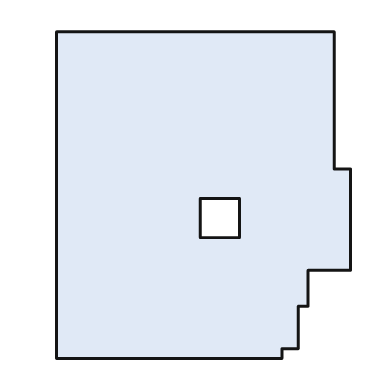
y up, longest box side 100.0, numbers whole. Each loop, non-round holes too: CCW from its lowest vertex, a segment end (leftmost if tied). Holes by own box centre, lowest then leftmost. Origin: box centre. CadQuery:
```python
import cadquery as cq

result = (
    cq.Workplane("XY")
    .moveTo(-45.0, -50.0)
    .lineTo(24.0, -50.0)
    .lineTo(24.0, -47.0)
    .lineTo(29.0, -47.0)
    .lineTo(29.0, -34.0)
    .lineTo(32.0, -34.0)
    .lineTo(32.0, -23.0)
    .lineTo(45.0, -23.0)
    .lineTo(45.0, 8.0)
    .lineTo(40.0, 8.0)
    .lineTo(40.0, 50.0)
    .lineTo(-45.0, 50.0)
    .close()
    .moveTo(-1.0, -13.0)
    .lineTo(11.0, -13.0)
    .lineTo(11.0, -1.0)
    .lineTo(-1.0, -1.0)
    .close()
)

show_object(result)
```